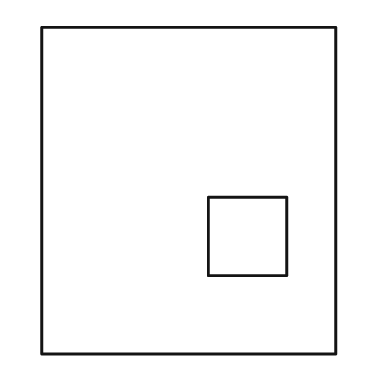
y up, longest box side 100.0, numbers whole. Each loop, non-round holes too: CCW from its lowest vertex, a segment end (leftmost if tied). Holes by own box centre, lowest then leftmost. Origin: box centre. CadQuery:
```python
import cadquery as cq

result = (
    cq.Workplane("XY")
    .moveTo(-45.0, -50.0)
    .lineTo(45.0, -50.0)
    .lineTo(45.0, 50.0)
    .lineTo(-45.0, 50.0)
    .close()
    .moveTo(6.0, -26.0)
    .lineTo(30.0, -26.0)
    .lineTo(30.0, -2.0)
    .lineTo(6.0, -2.0)
    .close()
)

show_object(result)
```